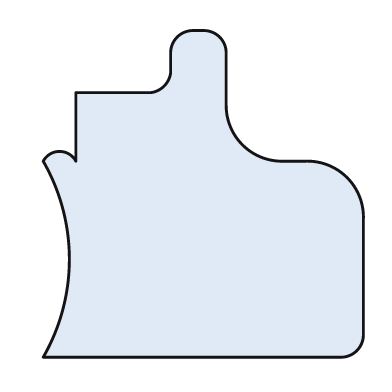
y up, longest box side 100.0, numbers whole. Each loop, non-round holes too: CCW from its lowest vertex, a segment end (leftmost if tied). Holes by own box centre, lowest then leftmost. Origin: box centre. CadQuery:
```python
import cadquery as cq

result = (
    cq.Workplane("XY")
    .moveTo(-49.0, -50.0)
    .lineTo(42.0, -50.0)
    .threePointArc((47.0, -48.0), (49.0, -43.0))
    .lineTo(49.0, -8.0)
    .threePointArc((44.0, 5.0), (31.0, 10.0))
    .lineTo(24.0, 10.0)
    .threePointArc((12.0, 15.0), (7.0, 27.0))
    .lineTo(7.0, 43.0)
    .threePointArc((5.0, 48.0), (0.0, 50.0))
    .lineTo(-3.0, 50.0)
    .threePointArc((-8.0, 48.0), (-10.0, 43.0))
    .lineTo(-10.0, 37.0)
    .threePointArc((-12.0, 33.0), (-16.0, 31.0))
    .lineTo(-39.0, 31.0)
    .lineTo(-39.0, 10.0)
    .threePointArc((-44.0, 13.0), (-49.0, 10.0))
    .threePointArc((-41.0, -20.0), (-49.0, -50.0))
    .close()
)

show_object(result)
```